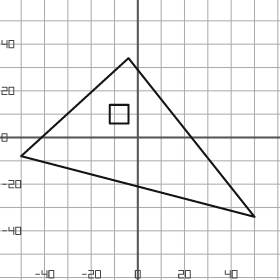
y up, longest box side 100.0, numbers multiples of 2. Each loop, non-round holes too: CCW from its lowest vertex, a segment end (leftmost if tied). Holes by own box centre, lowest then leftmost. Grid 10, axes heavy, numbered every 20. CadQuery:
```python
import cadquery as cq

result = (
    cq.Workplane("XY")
    .moveTo(50.0, -34.0)
    .lineTo(-4.0, 34.0)
    .lineTo(-50.0, -8.0)
    .close()
    .moveTo(-12.0, 6.0)
    .lineTo(-4.0, 6.0)
    .lineTo(-4.0, 14.0)
    .lineTo(-12.0, 14.0)
    .close()
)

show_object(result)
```